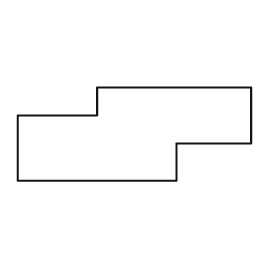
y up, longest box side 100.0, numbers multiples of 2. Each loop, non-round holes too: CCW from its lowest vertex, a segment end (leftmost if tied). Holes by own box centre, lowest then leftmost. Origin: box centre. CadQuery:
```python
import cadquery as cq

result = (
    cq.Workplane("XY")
    .moveTo(-50.0, -20.0)
    .lineTo(18.0, -20.0)
    .lineTo(18.0, -4.0)
    .lineTo(50.0, -4.0)
    .lineTo(50.0, 20.0)
    .lineTo(-16.0, 20.0)
    .lineTo(-16.0, 8.0)
    .lineTo(-50.0, 8.0)
    .close()
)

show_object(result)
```